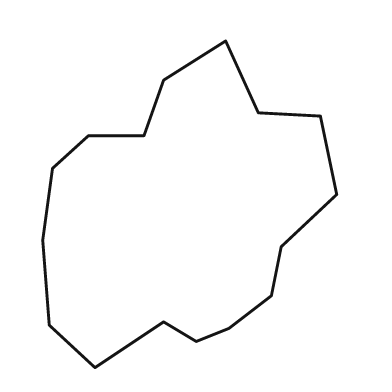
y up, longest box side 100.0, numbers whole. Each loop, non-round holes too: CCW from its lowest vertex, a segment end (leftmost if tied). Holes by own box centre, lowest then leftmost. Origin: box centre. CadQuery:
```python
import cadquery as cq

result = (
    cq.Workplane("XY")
    .moveTo(-29.0, -50.0)
    .lineTo(-8.0, -36.0)
    .lineTo(2.0, -42.0)
    .lineTo(12.0, -38.0)
    .lineTo(25.0, -28.0)
    .lineTo(28.0, -13.0)
    .lineTo(45.0, 3.0)
    .lineTo(40.0, 27.0)
    .lineTo(21.0, 28.0)
    .lineTo(11.0, 50.0)
    .lineTo(-8.0, 38.0)
    .lineTo(-14.0, 21.0)
    .lineTo(-31.0, 21.0)
    .lineTo(-42.0, 11.0)
    .lineTo(-45.0, -11.0)
    .lineTo(-43.0, -37.0)
    .close()
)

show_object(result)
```